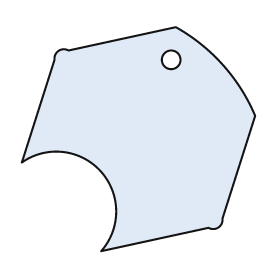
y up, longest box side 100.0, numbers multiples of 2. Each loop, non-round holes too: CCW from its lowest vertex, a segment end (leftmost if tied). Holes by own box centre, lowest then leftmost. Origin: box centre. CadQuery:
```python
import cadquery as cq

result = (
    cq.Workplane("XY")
    .moveTo(-16.0, -48.0)
    .lineTo(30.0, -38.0)
    .threePointArc((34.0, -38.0), (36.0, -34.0))
    .lineTo(50.0, 10.0)
    .threePointArc((36.0, 32.0), (16.0, 48.0))
    .lineTo(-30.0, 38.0)
    .threePointArc((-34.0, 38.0), (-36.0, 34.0))
    .lineTo(-50.0, -10.0)
    .threePointArc((-16.0, -14.0), (-16.0, -48.0))
    .close()
    .moveTo(14.0, 34.0)
    .circle(4.0)
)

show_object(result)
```